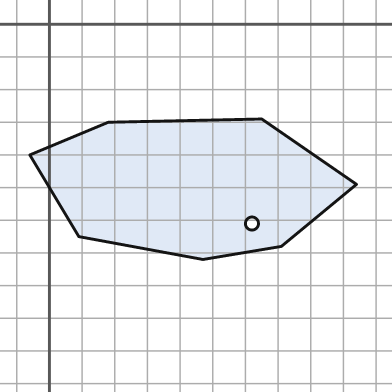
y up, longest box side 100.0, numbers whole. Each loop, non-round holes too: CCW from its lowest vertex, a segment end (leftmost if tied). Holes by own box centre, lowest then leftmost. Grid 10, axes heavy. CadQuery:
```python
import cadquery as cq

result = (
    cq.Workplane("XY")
    .moveTo(47.0, -72.0)
    .lineTo(71.0, -68.0)
    .lineTo(94.0, -49.0)
    .lineTo(65.0, -29.0)
    .lineTo(18.0, -30.0)
    .lineTo(-6.0, -40.0)
    .lineTo(9.0, -65.0)
    .close()
    .moveTo(62.0, -61.0)
    .circle(2.0)
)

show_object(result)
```